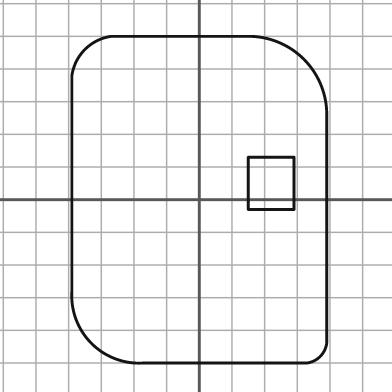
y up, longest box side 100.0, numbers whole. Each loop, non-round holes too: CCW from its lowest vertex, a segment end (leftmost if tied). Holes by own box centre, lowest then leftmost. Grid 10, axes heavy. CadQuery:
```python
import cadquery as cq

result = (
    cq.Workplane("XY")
    .moveTo(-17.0, -50.0)
    .lineTo(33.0, -50.0)
    .threePointArc((37.0, -48.0), (39.0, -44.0))
    .lineTo(39.0, 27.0)
    .threePointArc((32.0, 43.0), (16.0, 50.0))
    .lineTo(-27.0, 50.0)
    .threePointArc((-35.0, 46.0), (-39.0, 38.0))
    .lineTo(-39.0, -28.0)
    .threePointArc((-33.0, -44.0), (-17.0, -50.0))
    .close()
    .moveTo(15.0, -3.0)
    .lineTo(29.0, -3.0)
    .lineTo(29.0, 13.0)
    .lineTo(15.0, 13.0)
    .close()
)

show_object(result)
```